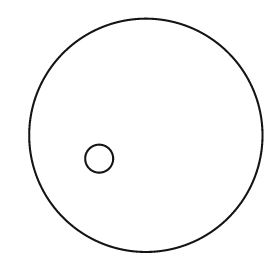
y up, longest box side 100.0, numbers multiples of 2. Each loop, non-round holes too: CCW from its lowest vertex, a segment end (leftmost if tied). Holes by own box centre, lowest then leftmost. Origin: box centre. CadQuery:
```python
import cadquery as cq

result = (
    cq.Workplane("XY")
    .moveTo(0.0, 0.0)
    .circle(50.0)
    .moveTo(-20.0, -10.0)
    .circle(6.0)
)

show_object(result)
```